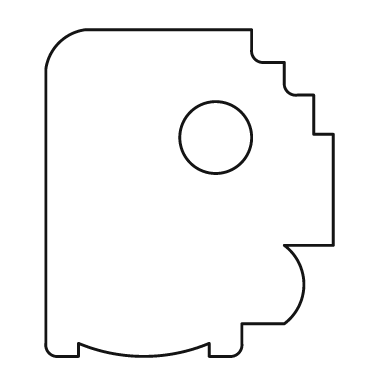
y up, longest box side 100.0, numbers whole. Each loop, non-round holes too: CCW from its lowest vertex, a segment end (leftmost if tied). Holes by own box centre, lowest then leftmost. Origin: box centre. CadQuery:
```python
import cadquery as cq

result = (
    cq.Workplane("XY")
    .moveTo(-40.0, -50.0)
    .lineTo(-34.0, -50.0)
    .lineTo(-34.0, -46.0)
    .threePointArc((-14.0, -50.0), (6.0, -46.0))
    .lineTo(6.0, -50.0)
    .lineTo(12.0, -50.0)
    .threePointArc((15.0, -49.0), (16.0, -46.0))
    .lineTo(16.0, -40.0)
    .lineTo(29.0, -40.0)
    .threePointArc((35.0, -28.0), (29.0, -16.0))
    .lineTo(44.0, -16.0)
    .lineTo(44.0, 18.0)
    .lineTo(38.0, 18.0)
    .lineTo(38.0, 30.0)
    .lineTo(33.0, 30.0)
    .threePointArc((30.0, 31.0), (29.0, 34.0))
    .lineTo(29.0, 40.0)
    .lineTo(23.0, 40.0)
    .threePointArc((20.0, 41.0), (19.0, 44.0))
    .lineTo(19.0, 50.0)
    .lineTo(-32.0, 50.0)
    .threePointArc((-40.0, 46.0), (-44.0, 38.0))
    .lineTo(-44.0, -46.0)
    .threePointArc((-43.0, -49.0), (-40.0, -50.0))
    .close()
    .moveTo(8.0, 17.0)
    .circle(11.0)
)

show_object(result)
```